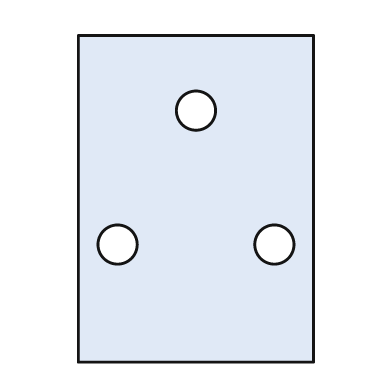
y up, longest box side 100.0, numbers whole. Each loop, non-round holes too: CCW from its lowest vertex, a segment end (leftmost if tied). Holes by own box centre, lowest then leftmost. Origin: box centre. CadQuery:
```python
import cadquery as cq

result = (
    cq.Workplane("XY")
    .moveTo(-36.0, -50.0)
    .lineTo(36.0, -50.0)
    .lineTo(36.0, 50.0)
    .lineTo(-36.0, 50.0)
    .close()
    .moveTo(-24.0, -14.0)
    .circle(6.0)
    .moveTo(24.0, -14.0)
    .circle(6.0)
    .moveTo(0.0, 27.0)
    .circle(6.0)
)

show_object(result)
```